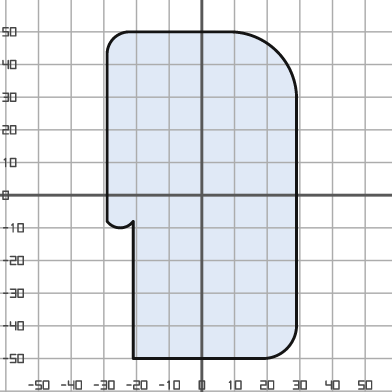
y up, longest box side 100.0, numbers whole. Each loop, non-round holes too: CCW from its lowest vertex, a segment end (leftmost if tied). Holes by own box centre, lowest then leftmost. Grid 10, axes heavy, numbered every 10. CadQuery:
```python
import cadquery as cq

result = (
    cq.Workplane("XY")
    .moveTo(-21.0, -50.0)
    .lineTo(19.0, -50.0)
    .threePointArc((26.0, -47.0), (29.0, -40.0))
    .lineTo(29.0, 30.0)
    .threePointArc((23.0, 44.0), (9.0, 50.0))
    .lineTo(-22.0, 50.0)
    .threePointArc((-27.0, 48.0), (-29.0, 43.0))
    .lineTo(-29.0, -8.0)
    .threePointArc((-25.0, -10.0), (-21.0, -8.0))
    .close()
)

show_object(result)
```